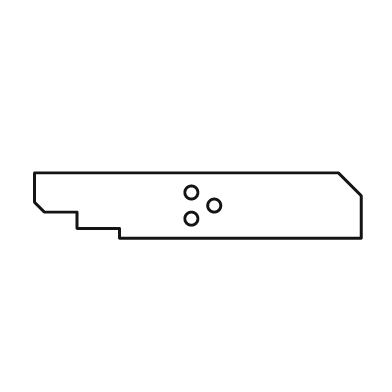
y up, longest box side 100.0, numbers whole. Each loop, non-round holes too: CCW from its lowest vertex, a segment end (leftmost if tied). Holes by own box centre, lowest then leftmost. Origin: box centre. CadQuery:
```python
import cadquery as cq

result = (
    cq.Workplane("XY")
    .moveTo(-24.0, -10.0)
    .lineTo(50.0, -10.0)
    .lineTo(50.0, 3.0)
    .lineTo(43.0, 10.0)
    .lineTo(-50.0, 10.0)
    .lineTo(-50.0, 1.0)
    .lineTo(-47.0, -2.0)
    .lineTo(-37.0, -2.0)
    .lineTo(-37.0, -7.0)
    .lineTo(-24.0, -7.0)
    .close()
    .moveTo(-2.0, -4.0)
    .circle(2.0)
    .moveTo(5.0, 0.0)
    .circle(2.0)
    .moveTo(-2.0, 4.0)
    .circle(2.0)
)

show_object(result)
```